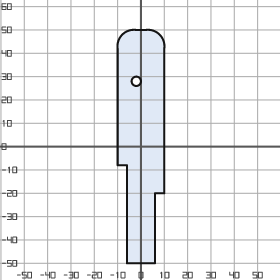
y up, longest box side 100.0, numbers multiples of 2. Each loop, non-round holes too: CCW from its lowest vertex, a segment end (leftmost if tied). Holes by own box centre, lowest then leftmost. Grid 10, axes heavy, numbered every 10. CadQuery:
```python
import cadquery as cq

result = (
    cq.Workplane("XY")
    .moveTo(-6.0, -50.0)
    .lineTo(6.0, -50.0)
    .lineTo(6.0, -20.0)
    .lineTo(10.0, -20.0)
    .lineTo(10.0, 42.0)
    .threePointArc((8.0, 48.0), (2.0, 50.0))
    .lineTo(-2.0, 50.0)
    .threePointArc((-8.0, 48.0), (-10.0, 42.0))
    .lineTo(-10.0, -8.0)
    .lineTo(-6.0, -8.0)
    .close()
    .moveTo(-2.0, 28.0)
    .circle(2.0)
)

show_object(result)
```